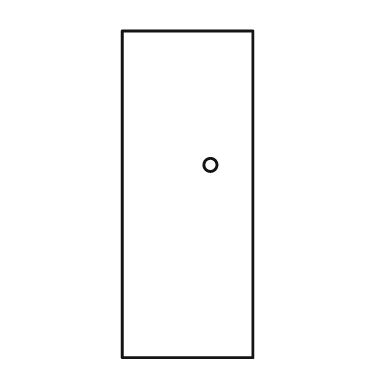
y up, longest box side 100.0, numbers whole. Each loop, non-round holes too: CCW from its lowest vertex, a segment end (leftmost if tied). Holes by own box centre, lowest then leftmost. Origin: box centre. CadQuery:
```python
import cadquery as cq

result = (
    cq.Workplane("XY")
    .moveTo(-20.0, -50.0)
    .lineTo(20.0, -50.0)
    .lineTo(20.0, 50.0)
    .lineTo(-20.0, 50.0)
    .close()
    .moveTo(7.0, 9.0)
    .circle(2.0)
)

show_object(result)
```